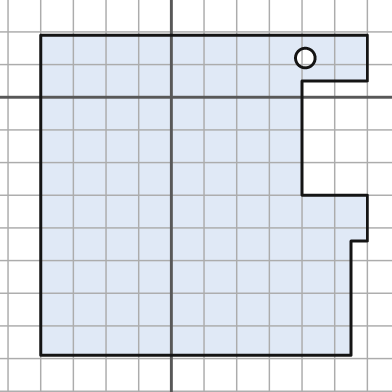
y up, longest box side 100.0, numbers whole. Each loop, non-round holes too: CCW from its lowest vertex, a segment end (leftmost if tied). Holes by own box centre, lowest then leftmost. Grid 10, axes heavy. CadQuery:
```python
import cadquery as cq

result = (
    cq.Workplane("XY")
    .moveTo(-40.0, -79.0)
    .lineTo(55.0, -79.0)
    .lineTo(55.0, -44.0)
    .lineTo(60.0, -44.0)
    .lineTo(60.0, -30.0)
    .lineTo(40.0, -30.0)
    .lineTo(40.0, 5.0)
    .lineTo(60.0, 5.0)
    .lineTo(60.0, 19.0)
    .lineTo(-40.0, 19.0)
    .close()
    .moveTo(41.0, 12.0)
    .circle(3.0)
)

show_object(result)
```